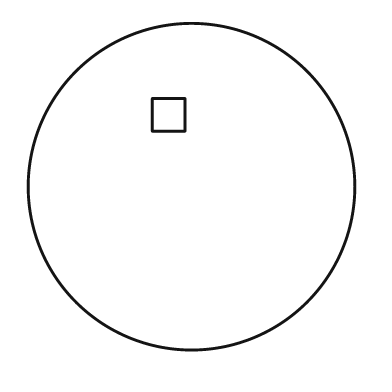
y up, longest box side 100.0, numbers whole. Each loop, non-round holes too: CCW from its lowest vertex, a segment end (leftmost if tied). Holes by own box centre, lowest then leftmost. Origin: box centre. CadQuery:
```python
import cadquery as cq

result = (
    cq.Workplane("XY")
    .moveTo(0.0, 0.0)
    .circle(50.0)
    .moveTo(-12.0, 17.0)
    .lineTo(-2.0, 17.0)
    .lineTo(-2.0, 27.0)
    .lineTo(-12.0, 27.0)
    .close()
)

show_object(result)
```